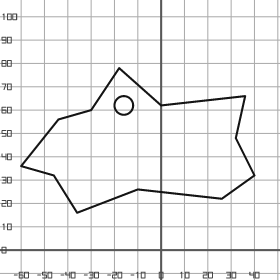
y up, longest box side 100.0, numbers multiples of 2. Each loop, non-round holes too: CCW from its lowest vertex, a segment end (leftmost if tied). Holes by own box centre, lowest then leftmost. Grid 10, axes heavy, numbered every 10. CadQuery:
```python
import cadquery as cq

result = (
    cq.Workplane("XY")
    .moveTo(-36.0, 16.0)
    .lineTo(-10.0, 26.0)
    .lineTo(26.0, 22.0)
    .lineTo(40.0, 32.0)
    .lineTo(32.0, 48.0)
    .lineTo(36.0, 66.0)
    .lineTo(0.0, 62.0)
    .lineTo(-18.0, 78.0)
    .lineTo(-30.0, 60.0)
    .lineTo(-44.0, 56.0)
    .lineTo(-60.0, 36.0)
    .lineTo(-46.0, 32.0)
    .close()
    .moveTo(-16.0, 62.0)
    .circle(4.0)
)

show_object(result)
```